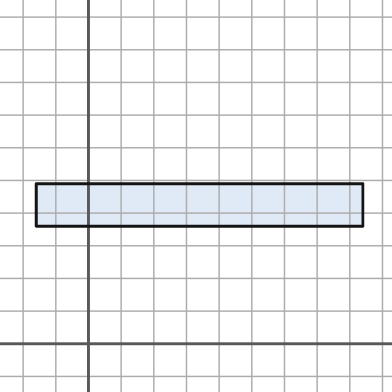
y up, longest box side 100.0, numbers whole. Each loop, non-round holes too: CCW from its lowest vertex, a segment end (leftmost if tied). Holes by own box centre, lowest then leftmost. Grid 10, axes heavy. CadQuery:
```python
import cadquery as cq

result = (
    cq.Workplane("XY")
    .moveTo(-16.0, 36.0)
    .lineTo(84.0, 36.0)
    .lineTo(84.0, 49.0)
    .lineTo(-16.0, 49.0)
    .close()
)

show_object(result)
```